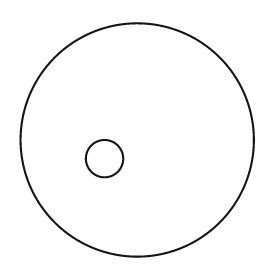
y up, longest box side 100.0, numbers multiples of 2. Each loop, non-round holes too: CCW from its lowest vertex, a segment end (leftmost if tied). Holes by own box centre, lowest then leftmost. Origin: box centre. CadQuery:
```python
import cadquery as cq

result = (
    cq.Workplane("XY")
    .moveTo(0.0, 0.0)
    .circle(50.0)
    .moveTo(-14.0, -8.0)
    .circle(8.0)
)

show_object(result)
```